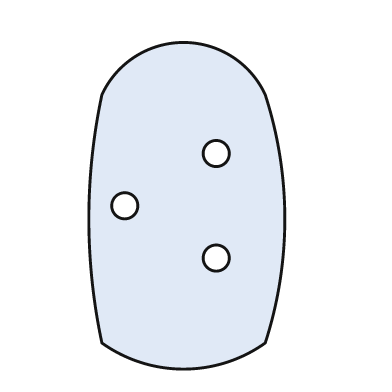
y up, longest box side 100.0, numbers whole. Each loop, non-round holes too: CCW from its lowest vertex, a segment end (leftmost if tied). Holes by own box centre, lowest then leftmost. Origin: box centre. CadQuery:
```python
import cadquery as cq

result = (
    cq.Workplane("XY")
    .moveTo(-26.0, -42.0)
    .threePointArc((-1.0, -50.0), (24.0, -42.0))
    .threePointArc((30.0, -4.0), (24.0, 34.0))
    .threePointArc((-1.0, 50.0), (-26.0, 34.0))
    .threePointArc((-30.0, -4.0), (-26.0, -42.0))
    .close()
    .moveTo(9.0, -16.0)
    .circle(4.0)
    .moveTo(-19.0, 0.0)
    .circle(4.0)
    .moveTo(9.0, 16.0)
    .circle(4.0)
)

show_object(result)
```